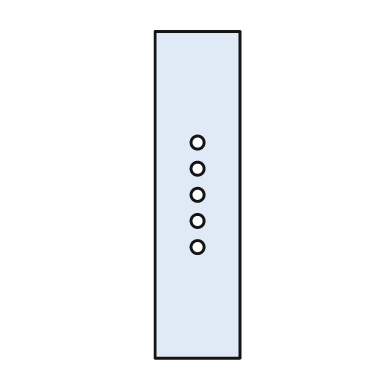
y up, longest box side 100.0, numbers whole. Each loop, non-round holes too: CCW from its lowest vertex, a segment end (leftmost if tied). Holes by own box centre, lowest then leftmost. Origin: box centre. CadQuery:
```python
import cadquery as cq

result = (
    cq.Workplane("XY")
    .moveTo(-13.0, -50.0)
    .lineTo(13.0, -50.0)
    .lineTo(13.0, 50.0)
    .lineTo(-13.0, 50.0)
    .close()
    .moveTo(0.0, -16.0)
    .circle(2.0)
    .moveTo(0.0, -8.0)
    .circle(2.0)
    .moveTo(0.0, 0.0)
    .circle(2.0)
    .moveTo(0.0, 8.0)
    .circle(2.0)
    .moveTo(0.0, 16.0)
    .circle(2.0)
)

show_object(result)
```